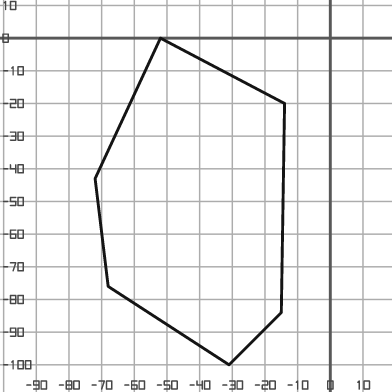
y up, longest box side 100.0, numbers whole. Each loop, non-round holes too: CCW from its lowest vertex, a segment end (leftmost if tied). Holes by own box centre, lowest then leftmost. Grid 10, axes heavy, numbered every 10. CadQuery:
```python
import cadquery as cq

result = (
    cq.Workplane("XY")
    .moveTo(-31.0, -100.0)
    .lineTo(-15.0, -84.0)
    .lineTo(-14.0, -20.0)
    .lineTo(-52.0, 0.0)
    .lineTo(-72.0, -43.0)
    .lineTo(-68.0, -76.0)
    .close()
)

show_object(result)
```